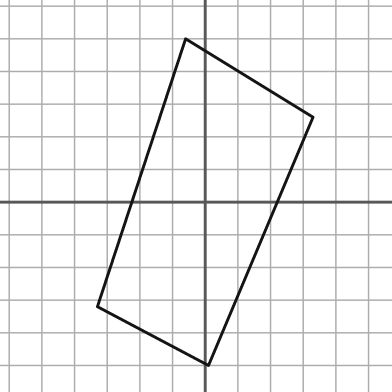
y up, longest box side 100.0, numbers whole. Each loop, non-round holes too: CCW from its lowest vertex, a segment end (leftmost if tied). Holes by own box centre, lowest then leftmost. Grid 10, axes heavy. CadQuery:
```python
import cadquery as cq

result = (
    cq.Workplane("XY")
    .moveTo(1.0, -50.0)
    .lineTo(33.0, 26.0)
    .lineTo(-6.0, 50.0)
    .lineTo(-33.0, -32.0)
    .close()
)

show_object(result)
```